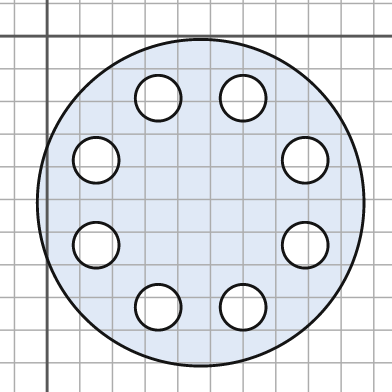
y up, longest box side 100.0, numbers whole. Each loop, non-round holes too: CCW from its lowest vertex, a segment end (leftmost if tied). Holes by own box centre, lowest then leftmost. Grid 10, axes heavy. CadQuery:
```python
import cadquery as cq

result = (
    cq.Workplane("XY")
    .moveTo(47.0, -51.0)
    .circle(50.0)
    .moveTo(34.0, -83.0)
    .circle(7.0)
    .moveTo(60.0, -83.0)
    .circle(7.0)
    .moveTo(15.0, -64.0)
    .circle(7.0)
    .moveTo(79.0, -64.0)
    .circle(7.0)
    .moveTo(15.0, -38.0)
    .circle(7.0)
    .moveTo(79.0, -38.0)
    .circle(7.0)
    .moveTo(34.0, -19.0)
    .circle(7.0)
    .moveTo(60.0, -19.0)
    .circle(7.0)
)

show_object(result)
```